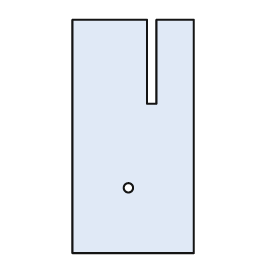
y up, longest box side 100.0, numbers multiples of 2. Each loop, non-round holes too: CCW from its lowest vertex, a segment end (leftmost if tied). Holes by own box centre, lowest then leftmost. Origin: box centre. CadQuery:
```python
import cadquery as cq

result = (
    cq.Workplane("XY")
    .moveTo(-26.0, -50.0)
    .lineTo(26.0, -50.0)
    .lineTo(26.0, 50.0)
    .lineTo(10.0, 50.0)
    .lineTo(10.0, 14.0)
    .lineTo(6.0, 14.0)
    .lineTo(6.0, 50.0)
    .lineTo(-26.0, 50.0)
    .close()
    .moveTo(-2.0, -22.0)
    .circle(2.0)
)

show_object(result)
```